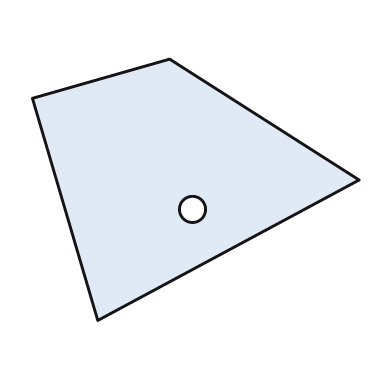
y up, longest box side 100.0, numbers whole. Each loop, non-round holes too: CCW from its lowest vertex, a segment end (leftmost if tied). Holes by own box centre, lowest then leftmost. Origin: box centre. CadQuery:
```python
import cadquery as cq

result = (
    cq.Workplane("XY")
    .moveTo(-30.0, -40.0)
    .lineTo(50.0, 3.0)
    .lineTo(-8.0, 40.0)
    .lineTo(-50.0, 28.0)
    .close()
    .moveTo(-1.0, -6.0)
    .circle(4.0)
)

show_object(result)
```